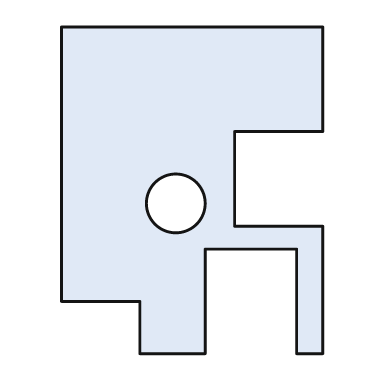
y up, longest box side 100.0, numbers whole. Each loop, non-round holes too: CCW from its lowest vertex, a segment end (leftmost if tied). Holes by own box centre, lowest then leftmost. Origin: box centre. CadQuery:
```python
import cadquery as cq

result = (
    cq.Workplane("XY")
    .moveTo(-16.0, -50.0)
    .lineTo(4.0, -50.0)
    .lineTo(4.0, -18.0)
    .lineTo(32.0, -18.0)
    .lineTo(32.0, -50.0)
    .lineTo(40.0, -50.0)
    .lineTo(40.0, -11.0)
    .lineTo(13.0, -11.0)
    .lineTo(13.0, 18.0)
    .lineTo(40.0, 18.0)
    .lineTo(40.0, 50.0)
    .lineTo(-40.0, 50.0)
    .lineTo(-40.0, -34.0)
    .lineTo(-16.0, -34.0)
    .close()
    .moveTo(-5.0, -4.0)
    .circle(9.0)
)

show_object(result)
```